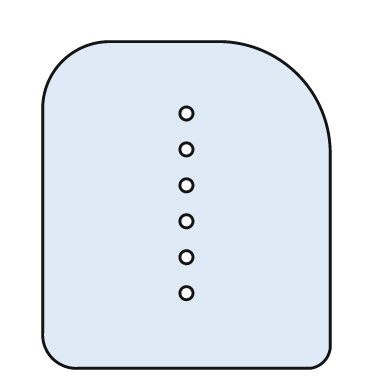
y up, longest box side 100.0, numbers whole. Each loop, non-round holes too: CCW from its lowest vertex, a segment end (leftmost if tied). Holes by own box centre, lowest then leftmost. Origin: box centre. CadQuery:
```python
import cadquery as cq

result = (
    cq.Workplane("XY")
    .moveTo(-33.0, -50.0)
    .lineTo(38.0, -50.0)
    .threePointArc((42.0, -48.0), (44.0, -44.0))
    .lineTo(44.0, 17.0)
    .threePointArc((34.0, 40.0), (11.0, 50.0))
    .lineTo(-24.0, 50.0)
    .threePointArc((-38.0, 44.0), (-44.0, 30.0))
    .lineTo(-44.0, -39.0)
    .threePointArc((-41.0, -47.0), (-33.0, -50.0))
    .close()
    .moveTo(0.0, -27.0)
    .circle(2.0)
    .moveTo(0.0, -16.0)
    .circle(2.0)
    .moveTo(0.0, -5.0)
    .circle(2.0)
    .moveTo(0.0, 6.0)
    .circle(2.0)
    .moveTo(0.0, 17.0)
    .circle(2.0)
    .moveTo(0.0, 28.0)
    .circle(2.0)
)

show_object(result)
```